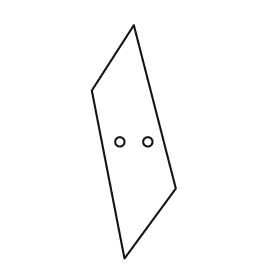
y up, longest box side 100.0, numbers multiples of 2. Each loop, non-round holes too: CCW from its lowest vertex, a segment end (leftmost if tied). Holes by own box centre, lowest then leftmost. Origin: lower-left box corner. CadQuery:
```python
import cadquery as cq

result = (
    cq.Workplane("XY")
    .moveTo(14.0, 0.0)
    .lineTo(36.0, 30.0)
    .lineTo(18.0, 100.0)
    .lineTo(0.0, 72.0)
    .close()
    .moveTo(12.0, 50.0)
    .circle(2.0)
    .moveTo(24.0, 50.0)
    .circle(2.0)
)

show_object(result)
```